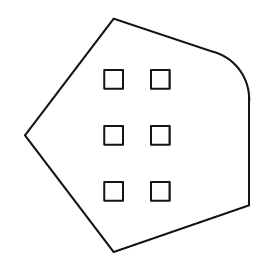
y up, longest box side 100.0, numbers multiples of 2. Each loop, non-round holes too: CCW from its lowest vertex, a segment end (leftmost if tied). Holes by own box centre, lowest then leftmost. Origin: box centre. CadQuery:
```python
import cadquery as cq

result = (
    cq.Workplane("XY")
    .moveTo(-10.0, -50.0)
    .lineTo(48.0, -30.0)
    .lineTo(48.0, 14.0)
    .threePointArc((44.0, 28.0), (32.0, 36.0))
    .lineTo(-10.0, 50.0)
    .lineTo(-48.0, 0.0)
    .close()
    .moveTo(-14.0, -28.0)
    .lineTo(-6.0, -28.0)
    .lineTo(-6.0, -20.0)
    .lineTo(-14.0, -20.0)
    .close()
    .moveTo(6.0, -28.0)
    .lineTo(14.0, -28.0)
    .lineTo(14.0, -20.0)
    .lineTo(6.0, -20.0)
    .close()
    .moveTo(-14.0, -4.0)
    .lineTo(-6.0, -4.0)
    .lineTo(-6.0, 4.0)
    .lineTo(-14.0, 4.0)
    .close()
    .moveTo(6.0, -4.0)
    .lineTo(14.0, -4.0)
    .lineTo(14.0, 4.0)
    .lineTo(6.0, 4.0)
    .close()
    .moveTo(-14.0, 20.0)
    .lineTo(-6.0, 20.0)
    .lineTo(-6.0, 28.0)
    .lineTo(-14.0, 28.0)
    .close()
    .moveTo(6.0, 20.0)
    .lineTo(14.0, 20.0)
    .lineTo(14.0, 28.0)
    .lineTo(6.0, 28.0)
    .close()
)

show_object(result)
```